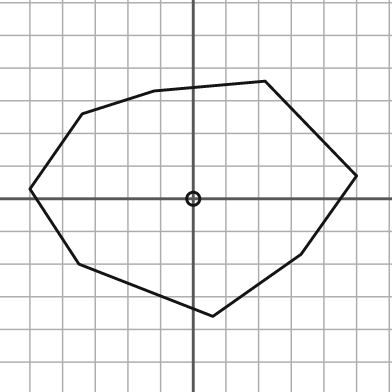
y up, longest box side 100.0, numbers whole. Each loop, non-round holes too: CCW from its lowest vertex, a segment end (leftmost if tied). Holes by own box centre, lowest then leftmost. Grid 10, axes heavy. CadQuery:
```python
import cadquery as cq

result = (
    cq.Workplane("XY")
    .moveTo(6.0, -36.0)
    .lineTo(33.0, -17.0)
    .lineTo(50.0, 7.0)
    .lineTo(22.0, 36.0)
    .lineTo(-12.0, 33.0)
    .lineTo(-34.0, 26.0)
    .lineTo(-50.0, 3.0)
    .lineTo(-35.0, -20.0)
    .close()
    .moveTo(0.0, 0.0)
    .circle(2.0)
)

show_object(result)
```